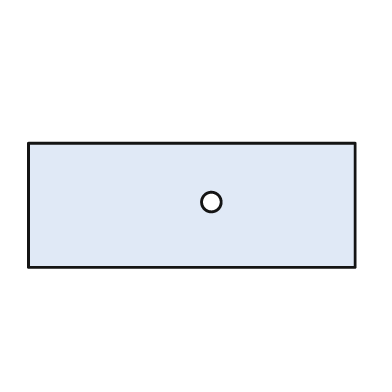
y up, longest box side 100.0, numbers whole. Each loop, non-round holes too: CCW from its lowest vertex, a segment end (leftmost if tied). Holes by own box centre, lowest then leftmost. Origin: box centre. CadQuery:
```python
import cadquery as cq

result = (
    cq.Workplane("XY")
    .moveTo(-50.0, -19.0)
    .lineTo(50.0, -19.0)
    .lineTo(50.0, 19.0)
    .lineTo(-50.0, 19.0)
    .close()
    .moveTo(6.0, 1.0)
    .circle(3.0)
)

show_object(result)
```